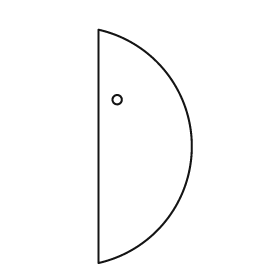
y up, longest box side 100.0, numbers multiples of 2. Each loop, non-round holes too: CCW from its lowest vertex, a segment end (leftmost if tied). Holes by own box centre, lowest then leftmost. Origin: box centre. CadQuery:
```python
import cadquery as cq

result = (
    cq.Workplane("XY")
    .moveTo(-20.0, -50.0)
    .threePointArc((20.0, 0.0), (-20.0, 50.0))
    .close()
    .moveTo(-12.0, 20.0)
    .circle(2.0)
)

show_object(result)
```